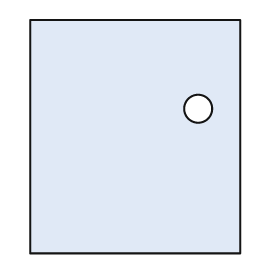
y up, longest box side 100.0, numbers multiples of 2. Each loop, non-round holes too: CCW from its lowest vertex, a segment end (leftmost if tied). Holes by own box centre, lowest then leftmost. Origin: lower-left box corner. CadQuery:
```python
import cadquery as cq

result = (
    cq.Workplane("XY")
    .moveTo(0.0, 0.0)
    .lineTo(90.0, 0.0)
    .lineTo(90.0, 100.0)
    .lineTo(0.0, 100.0)
    .close()
    .moveTo(72.0, 62.0)
    .circle(6.0)
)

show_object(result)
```